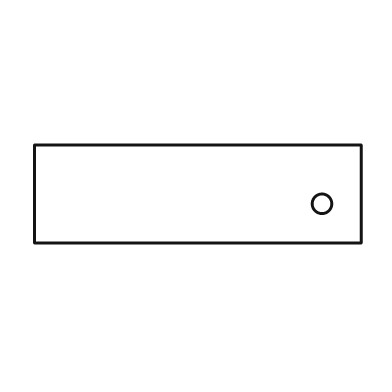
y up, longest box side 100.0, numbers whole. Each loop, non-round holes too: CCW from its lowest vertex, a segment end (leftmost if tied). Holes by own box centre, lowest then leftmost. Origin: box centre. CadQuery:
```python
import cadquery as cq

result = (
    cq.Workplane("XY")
    .moveTo(-50.0, -15.0)
    .lineTo(50.0, -15.0)
    .lineTo(50.0, 15.0)
    .lineTo(-50.0, 15.0)
    .close()
    .moveTo(38.0, -3.0)
    .circle(3.0)
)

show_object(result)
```